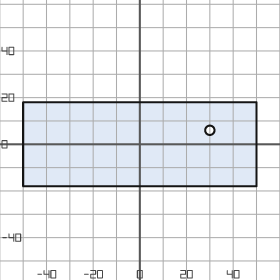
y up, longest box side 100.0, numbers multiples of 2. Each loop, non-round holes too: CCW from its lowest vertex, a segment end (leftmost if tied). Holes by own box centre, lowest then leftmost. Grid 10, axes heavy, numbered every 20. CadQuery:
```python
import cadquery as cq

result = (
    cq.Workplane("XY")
    .moveTo(-50.0, -18.0)
    .lineTo(50.0, -18.0)
    .lineTo(50.0, 18.0)
    .lineTo(-50.0, 18.0)
    .close()
    .moveTo(30.0, 6.0)
    .circle(2.0)
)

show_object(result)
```